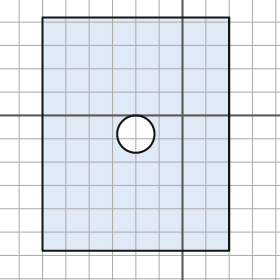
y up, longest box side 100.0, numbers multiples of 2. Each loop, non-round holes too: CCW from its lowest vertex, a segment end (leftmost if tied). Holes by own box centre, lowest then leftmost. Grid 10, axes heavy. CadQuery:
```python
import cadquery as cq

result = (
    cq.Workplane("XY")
    .moveTo(-60.0, -58.0)
    .lineTo(20.0, -58.0)
    .lineTo(20.0, 42.0)
    .lineTo(-60.0, 42.0)
    .close()
    .moveTo(-20.0, -8.0)
    .circle(8.0)
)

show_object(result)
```